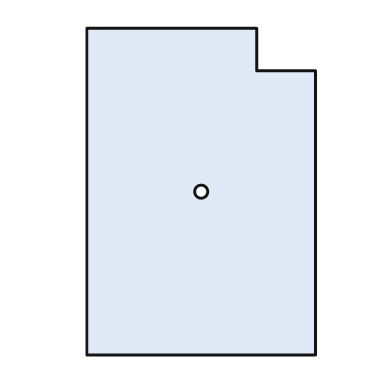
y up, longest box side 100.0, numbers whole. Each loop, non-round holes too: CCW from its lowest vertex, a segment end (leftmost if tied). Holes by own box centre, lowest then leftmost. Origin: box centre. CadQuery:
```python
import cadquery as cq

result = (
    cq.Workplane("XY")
    .moveTo(-35.0, -50.0)
    .lineTo(35.0, -50.0)
    .lineTo(35.0, 37.0)
    .lineTo(17.0, 37.0)
    .lineTo(17.0, 50.0)
    .lineTo(-35.0, 50.0)
    .close()
    .moveTo(0.0, 0.0)
    .circle(2.0)
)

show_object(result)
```